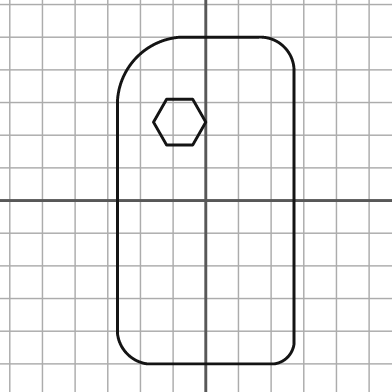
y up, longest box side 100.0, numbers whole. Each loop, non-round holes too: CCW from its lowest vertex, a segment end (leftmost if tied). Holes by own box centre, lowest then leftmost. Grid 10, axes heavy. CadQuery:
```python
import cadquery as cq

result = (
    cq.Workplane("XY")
    .moveTo(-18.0, -50.0)
    .lineTo(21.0, -50.0)
    .threePointArc((25.0, -48.0), (27.0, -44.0))
    .lineTo(27.0, 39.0)
    .threePointArc((24.0, 47.0), (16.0, 50.0))
    .lineTo(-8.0, 50.0)
    .threePointArc((-21.0, 44.0), (-27.0, 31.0))
    .lineTo(-27.0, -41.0)
    .threePointArc((-24.0, -47.0), (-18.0, -50.0))
    .close()
    .moveTo(-12.0, 17.0)
    .lineTo(-4.0, 17.0)
    .lineTo(0.0, 24.0)
    .lineTo(-4.0, 31.0)
    .lineTo(-12.0, 31.0)
    .lineTo(-16.0, 24.0)
    .close()
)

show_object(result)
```